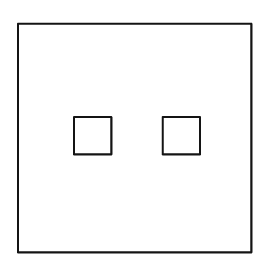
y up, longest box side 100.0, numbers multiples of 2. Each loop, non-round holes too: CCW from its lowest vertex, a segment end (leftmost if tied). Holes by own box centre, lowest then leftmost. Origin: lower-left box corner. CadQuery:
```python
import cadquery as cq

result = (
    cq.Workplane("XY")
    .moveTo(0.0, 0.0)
    .lineTo(100.0, 0.0)
    .lineTo(100.0, 98.0)
    .lineTo(0.0, 98.0)
    .close()
    .moveTo(24.0, 42.0)
    .lineTo(40.0, 42.0)
    .lineTo(40.0, 58.0)
    .lineTo(24.0, 58.0)
    .close()
    .moveTo(62.0, 42.0)
    .lineTo(78.0, 42.0)
    .lineTo(78.0, 58.0)
    .lineTo(62.0, 58.0)
    .close()
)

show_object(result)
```